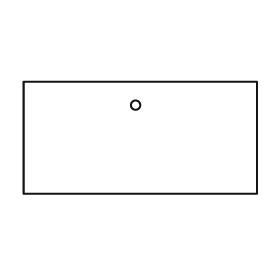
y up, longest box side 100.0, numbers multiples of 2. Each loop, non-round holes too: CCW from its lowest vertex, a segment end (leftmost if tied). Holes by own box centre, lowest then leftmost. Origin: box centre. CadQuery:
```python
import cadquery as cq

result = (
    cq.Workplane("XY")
    .moveTo(-50.0, -24.0)
    .lineTo(50.0, -24.0)
    .lineTo(50.0, 24.0)
    .lineTo(-50.0, 24.0)
    .close()
    .moveTo(-2.0, 14.0)
    .circle(2.0)
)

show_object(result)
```